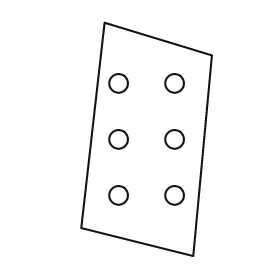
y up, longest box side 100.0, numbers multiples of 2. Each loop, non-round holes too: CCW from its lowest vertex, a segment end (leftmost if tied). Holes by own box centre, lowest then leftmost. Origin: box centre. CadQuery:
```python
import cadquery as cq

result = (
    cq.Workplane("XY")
    .moveTo(20.0, -50.0)
    .lineTo(28.0, 36.0)
    .lineTo(-18.0, 50.0)
    .lineTo(-28.0, -38.0)
    .close()
    .moveTo(-12.0, -24.0)
    .circle(4.0)
    .moveTo(12.0, -24.0)
    .circle(4.0)
    .moveTo(-12.0, 0.0)
    .circle(4.0)
    .moveTo(12.0, 0.0)
    .circle(4.0)
    .moveTo(-12.0, 24.0)
    .circle(4.0)
    .moveTo(12.0, 24.0)
    .circle(4.0)
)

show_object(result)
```